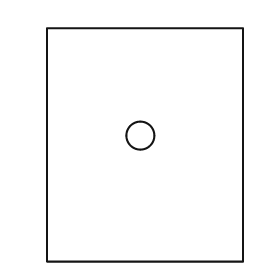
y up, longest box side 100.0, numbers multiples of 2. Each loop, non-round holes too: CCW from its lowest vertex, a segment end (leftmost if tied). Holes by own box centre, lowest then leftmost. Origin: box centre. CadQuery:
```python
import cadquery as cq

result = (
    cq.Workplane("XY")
    .moveTo(-42.0, -50.0)
    .lineTo(42.0, -50.0)
    .lineTo(42.0, 50.0)
    .lineTo(-42.0, 50.0)
    .close()
    .moveTo(-2.0, 4.0)
    .circle(6.0)
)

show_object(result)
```